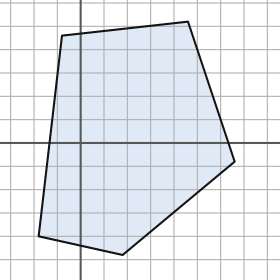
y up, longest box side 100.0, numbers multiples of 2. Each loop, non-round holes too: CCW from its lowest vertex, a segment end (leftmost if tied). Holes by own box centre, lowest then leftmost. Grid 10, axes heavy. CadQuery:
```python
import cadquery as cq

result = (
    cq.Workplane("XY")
    .moveTo(18.0, -48.0)
    .lineTo(66.0, -8.0)
    .lineTo(46.0, 52.0)
    .lineTo(-8.0, 46.0)
    .lineTo(-18.0, -40.0)
    .close()
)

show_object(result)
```